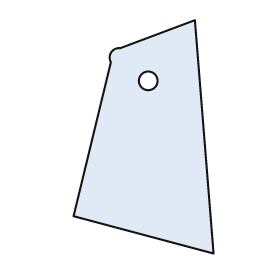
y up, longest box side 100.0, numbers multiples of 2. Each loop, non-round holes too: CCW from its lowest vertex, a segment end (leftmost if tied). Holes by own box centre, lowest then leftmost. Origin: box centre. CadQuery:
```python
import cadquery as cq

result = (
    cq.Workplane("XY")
    .moveTo(30.0, -50.0)
    .lineTo(22.0, 50.0)
    .lineTo(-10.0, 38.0)
    .threePointArc((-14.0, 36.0), (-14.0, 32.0))
    .lineTo(-30.0, -34.0)
    .close()
    .moveTo(2.0, 24.0)
    .circle(4.0)
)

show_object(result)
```